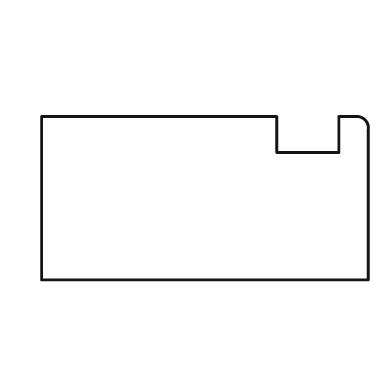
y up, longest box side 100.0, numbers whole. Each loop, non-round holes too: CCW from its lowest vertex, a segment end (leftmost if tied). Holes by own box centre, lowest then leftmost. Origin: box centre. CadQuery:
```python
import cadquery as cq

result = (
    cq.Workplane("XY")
    .moveTo(-50.0, -25.0)
    .lineTo(50.0, -25.0)
    .lineTo(50.0, 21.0)
    .threePointArc((49.0, 24.0), (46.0, 25.0))
    .lineTo(41.0, 25.0)
    .lineTo(41.0, 14.0)
    .lineTo(22.0, 14.0)
    .lineTo(22.0, 25.0)
    .lineTo(-50.0, 25.0)
    .close()
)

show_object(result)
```